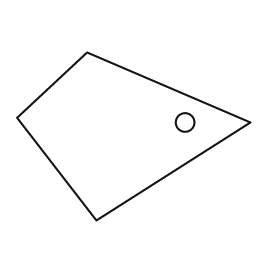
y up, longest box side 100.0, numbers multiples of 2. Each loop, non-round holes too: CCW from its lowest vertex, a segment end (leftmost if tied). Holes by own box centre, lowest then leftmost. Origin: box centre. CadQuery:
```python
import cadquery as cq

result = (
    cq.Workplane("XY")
    .moveTo(-16.0, -36.0)
    .lineTo(50.0, 6.0)
    .lineTo(-20.0, 36.0)
    .lineTo(-50.0, 8.0)
    .close()
    .moveTo(22.0, 6.0)
    .circle(4.0)
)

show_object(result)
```